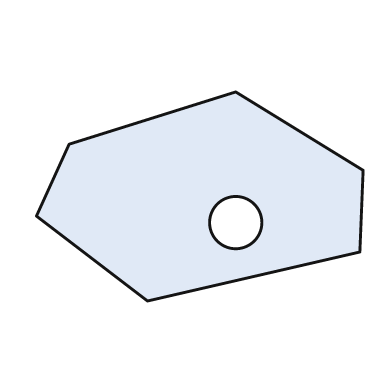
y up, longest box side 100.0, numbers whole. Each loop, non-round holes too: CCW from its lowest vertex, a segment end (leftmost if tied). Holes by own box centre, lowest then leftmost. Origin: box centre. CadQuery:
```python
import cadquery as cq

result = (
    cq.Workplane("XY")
    .moveTo(-16.0, -32.0)
    .lineTo(49.0, -17.0)
    .lineTo(50.0, 8.0)
    .lineTo(11.0, 32.0)
    .lineTo(-40.0, 16.0)
    .lineTo(-50.0, -6.0)
    .close()
    .moveTo(11.0, -8.0)
    .circle(8.0)
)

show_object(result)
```